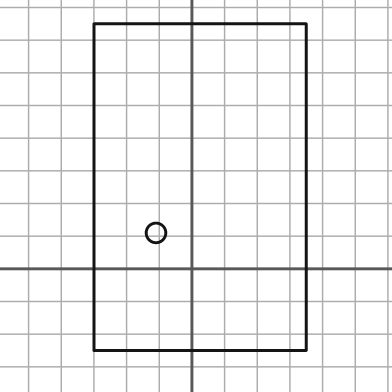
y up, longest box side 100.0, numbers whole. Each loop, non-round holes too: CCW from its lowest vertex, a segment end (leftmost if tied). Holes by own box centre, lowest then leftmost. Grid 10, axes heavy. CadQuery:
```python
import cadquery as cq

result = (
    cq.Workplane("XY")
    .moveTo(-30.0, -25.0)
    .lineTo(35.0, -25.0)
    .lineTo(35.0, 75.0)
    .lineTo(-30.0, 75.0)
    .close()
    .moveTo(-11.0, 11.0)
    .circle(3.0)
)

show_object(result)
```